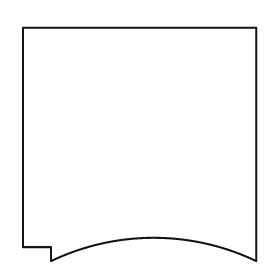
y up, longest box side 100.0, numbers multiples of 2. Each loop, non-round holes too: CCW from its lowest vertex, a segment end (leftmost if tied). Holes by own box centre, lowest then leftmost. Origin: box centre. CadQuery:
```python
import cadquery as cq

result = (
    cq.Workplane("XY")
    .moveTo(-38.0, -50.0)
    .threePointArc((6.0, -40.0), (50.0, -50.0))
    .lineTo(50.0, 50.0)
    .lineTo(-50.0, 50.0)
    .lineTo(-50.0, -44.0)
    .lineTo(-38.0, -44.0)
    .close()
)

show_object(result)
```